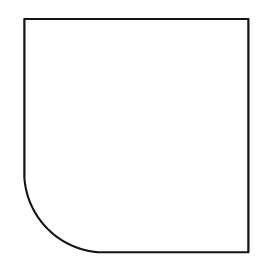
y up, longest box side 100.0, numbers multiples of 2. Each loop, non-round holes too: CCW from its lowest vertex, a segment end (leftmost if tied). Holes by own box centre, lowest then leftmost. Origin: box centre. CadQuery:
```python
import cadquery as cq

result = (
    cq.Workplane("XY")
    .moveTo(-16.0, -50.0)
    .lineTo(48.0, -50.0)
    .lineTo(48.0, 50.0)
    .lineTo(-48.0, 50.0)
    .lineTo(-48.0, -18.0)
    .threePointArc((-38.0, -40.0), (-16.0, -50.0))
    .close()
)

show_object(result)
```